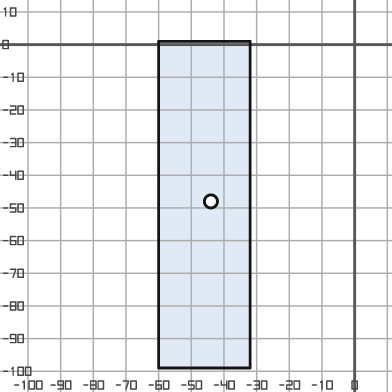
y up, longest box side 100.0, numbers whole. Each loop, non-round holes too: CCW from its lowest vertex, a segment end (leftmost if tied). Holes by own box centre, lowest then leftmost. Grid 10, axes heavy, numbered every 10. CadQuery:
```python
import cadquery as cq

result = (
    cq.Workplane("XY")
    .moveTo(-60.0, -99.0)
    .lineTo(-32.0, -99.0)
    .lineTo(-32.0, 1.0)
    .lineTo(-60.0, 1.0)
    .close()
    .moveTo(-44.0, -48.0)
    .circle(2.0)
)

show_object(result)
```